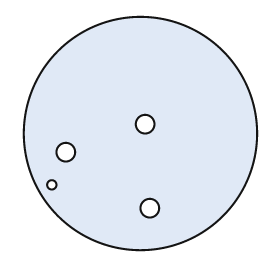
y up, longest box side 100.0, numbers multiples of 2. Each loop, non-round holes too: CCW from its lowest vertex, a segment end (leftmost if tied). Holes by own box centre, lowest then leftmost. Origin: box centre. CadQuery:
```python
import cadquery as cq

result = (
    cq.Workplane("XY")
    .moveTo(0.0, 0.0)
    .circle(50.0)
    .moveTo(4.0, -32.0)
    .circle(4.0)
    .moveTo(-38.0, -22.0)
    .circle(2.0)
    .moveTo(-32.0, -8.0)
    .circle(4.0)
    .moveTo(2.0, 4.0)
    .circle(4.0)
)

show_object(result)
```